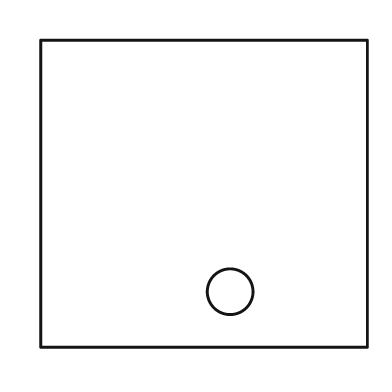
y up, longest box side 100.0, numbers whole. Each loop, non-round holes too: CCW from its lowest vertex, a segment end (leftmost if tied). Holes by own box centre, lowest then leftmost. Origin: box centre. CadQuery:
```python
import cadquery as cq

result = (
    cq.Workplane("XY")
    .moveTo(-50.0, -47.0)
    .lineTo(50.0, -47.0)
    .lineTo(50.0, 47.0)
    .lineTo(-50.0, 47.0)
    .close()
    .moveTo(8.0, -30.0)
    .circle(7.0)
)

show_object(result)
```